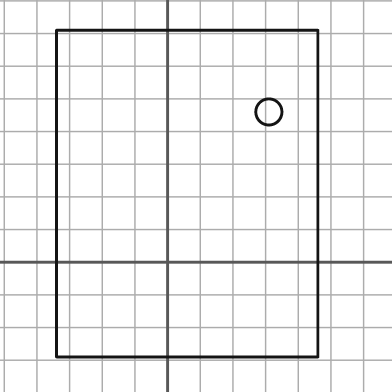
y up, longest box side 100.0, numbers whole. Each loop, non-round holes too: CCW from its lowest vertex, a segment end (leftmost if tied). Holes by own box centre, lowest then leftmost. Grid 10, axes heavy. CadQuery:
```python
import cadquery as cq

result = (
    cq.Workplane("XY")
    .moveTo(-34.0, -29.0)
    .lineTo(46.0, -29.0)
    .lineTo(46.0, 71.0)
    .lineTo(-34.0, 71.0)
    .close()
    .moveTo(31.0, 46.0)
    .circle(4.0)
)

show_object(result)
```